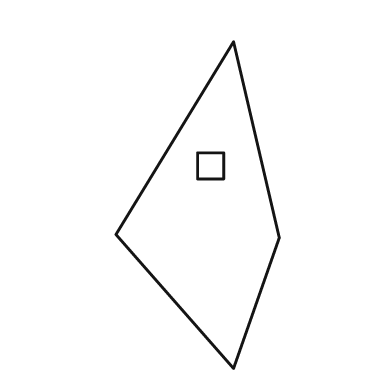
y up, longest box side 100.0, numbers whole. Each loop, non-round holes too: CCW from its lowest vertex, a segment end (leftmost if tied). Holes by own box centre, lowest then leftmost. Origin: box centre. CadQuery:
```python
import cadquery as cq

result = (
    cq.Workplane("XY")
    .moveTo(11.0, -50.0)
    .lineTo(25.0, -10.0)
    .lineTo(11.0, 50.0)
    .lineTo(-25.0, -9.0)
    .close()
    .moveTo(0.0, 8.0)
    .lineTo(8.0, 8.0)
    .lineTo(8.0, 16.0)
    .lineTo(0.0, 16.0)
    .close()
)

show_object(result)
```